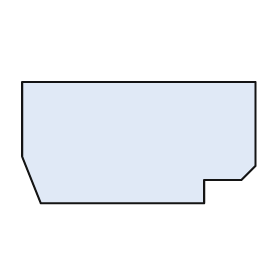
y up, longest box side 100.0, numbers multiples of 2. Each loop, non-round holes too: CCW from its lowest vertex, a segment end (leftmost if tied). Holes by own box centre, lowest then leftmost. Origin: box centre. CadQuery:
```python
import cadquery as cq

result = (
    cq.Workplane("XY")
    .moveTo(-42.0, -26.0)
    .lineTo(28.0, -26.0)
    .lineTo(28.0, -16.0)
    .lineTo(44.0, -16.0)
    .lineTo(50.0, -10.0)
    .lineTo(50.0, 26.0)
    .lineTo(-50.0, 26.0)
    .lineTo(-50.0, -6.0)
    .close()
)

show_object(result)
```